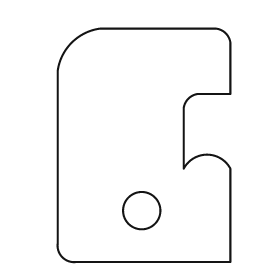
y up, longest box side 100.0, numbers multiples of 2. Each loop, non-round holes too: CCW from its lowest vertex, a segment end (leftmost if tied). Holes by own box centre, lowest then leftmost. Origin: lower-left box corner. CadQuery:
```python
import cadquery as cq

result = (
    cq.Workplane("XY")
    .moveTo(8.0, 0.0)
    .lineTo(74.0, 0.0)
    .lineTo(74.0, 40.0)
    .threePointArc((64.0, 46.0), (54.0, 40.0))
    .lineTo(54.0, 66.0)
    .threePointArc((56.0, 70.0), (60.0, 72.0))
    .lineTo(74.0, 72.0)
    .lineTo(74.0, 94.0)
    .threePointArc((72.0, 98.0), (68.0, 100.0))
    .lineTo(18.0, 100.0)
    .threePointArc((6.0, 94.0), (0.0, 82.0))
    .lineTo(0.0, 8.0)
    .threePointArc((2.0, 2.0), (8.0, 0.0))
    .close()
    .moveTo(36.0, 22.0)
    .circle(8.0)
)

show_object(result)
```